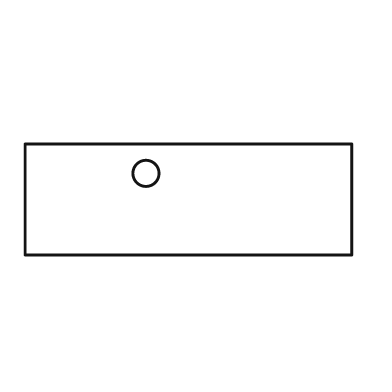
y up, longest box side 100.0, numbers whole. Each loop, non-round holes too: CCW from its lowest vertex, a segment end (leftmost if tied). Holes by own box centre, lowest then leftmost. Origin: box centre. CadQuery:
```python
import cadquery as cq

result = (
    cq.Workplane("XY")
    .moveTo(-50.0, -17.0)
    .lineTo(50.0, -17.0)
    .lineTo(50.0, 17.0)
    .lineTo(-50.0, 17.0)
    .close()
    .moveTo(-13.0, 8.0)
    .circle(4.0)
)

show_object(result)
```